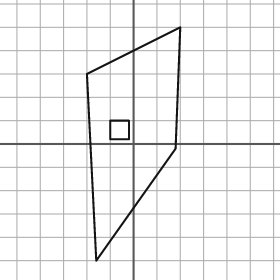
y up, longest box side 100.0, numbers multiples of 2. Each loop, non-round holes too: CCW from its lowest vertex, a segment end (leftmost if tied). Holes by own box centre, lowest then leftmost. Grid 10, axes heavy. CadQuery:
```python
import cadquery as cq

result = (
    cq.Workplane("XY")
    .moveTo(-16.0, -50.0)
    .lineTo(18.0, -2.0)
    .lineTo(20.0, 50.0)
    .lineTo(-20.0, 30.0)
    .close()
    .moveTo(-10.0, 2.0)
    .lineTo(-2.0, 2.0)
    .lineTo(-2.0, 10.0)
    .lineTo(-10.0, 10.0)
    .close()
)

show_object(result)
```